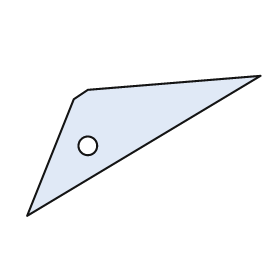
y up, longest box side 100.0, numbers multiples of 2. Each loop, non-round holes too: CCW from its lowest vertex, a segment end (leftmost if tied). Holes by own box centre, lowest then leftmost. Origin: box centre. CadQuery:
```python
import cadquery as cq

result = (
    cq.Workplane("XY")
    .moveTo(-50.0, -30.0)
    .lineTo(50.0, 30.0)
    .lineTo(-24.0, 24.0)
    .lineTo(-30.0, 20.0)
    .close()
    .moveTo(-24.0, 0.0)
    .circle(4.0)
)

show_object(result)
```